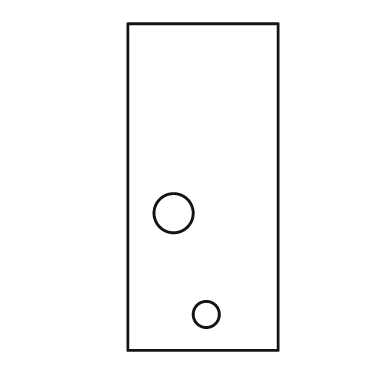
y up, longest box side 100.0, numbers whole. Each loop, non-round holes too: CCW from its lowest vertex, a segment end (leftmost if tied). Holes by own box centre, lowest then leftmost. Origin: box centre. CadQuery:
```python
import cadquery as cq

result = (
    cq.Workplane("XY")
    .moveTo(-23.0, -50.0)
    .lineTo(23.0, -50.0)
    .lineTo(23.0, 50.0)
    .lineTo(-23.0, 50.0)
    .close()
    .moveTo(1.0, -39.0)
    .circle(4.0)
    .moveTo(-9.0, -8.0)
    .circle(6.0)
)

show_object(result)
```